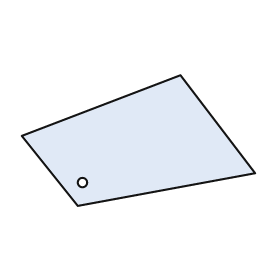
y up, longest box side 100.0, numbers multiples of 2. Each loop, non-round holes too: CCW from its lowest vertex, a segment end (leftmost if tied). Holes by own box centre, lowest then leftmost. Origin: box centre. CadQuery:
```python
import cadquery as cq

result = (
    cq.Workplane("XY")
    .moveTo(-26.0, -28.0)
    .lineTo(50.0, -14.0)
    .lineTo(18.0, 28.0)
    .lineTo(-50.0, 2.0)
    .close()
    .moveTo(-24.0, -18.0)
    .circle(2.0)
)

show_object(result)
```